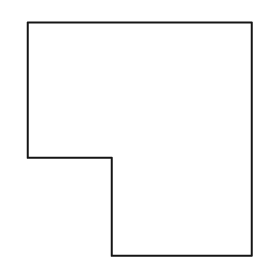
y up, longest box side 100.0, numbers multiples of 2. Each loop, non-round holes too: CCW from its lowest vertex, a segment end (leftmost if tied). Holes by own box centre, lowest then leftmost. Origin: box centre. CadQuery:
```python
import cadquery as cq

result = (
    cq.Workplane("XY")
    .moveTo(-12.0, -50.0)
    .lineTo(48.0, -50.0)
    .lineTo(48.0, 50.0)
    .lineTo(-48.0, 50.0)
    .lineTo(-48.0, -8.0)
    .lineTo(-12.0, -8.0)
    .close()
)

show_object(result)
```